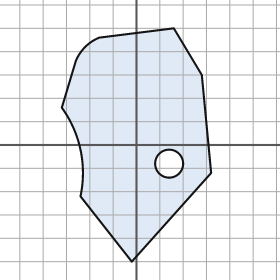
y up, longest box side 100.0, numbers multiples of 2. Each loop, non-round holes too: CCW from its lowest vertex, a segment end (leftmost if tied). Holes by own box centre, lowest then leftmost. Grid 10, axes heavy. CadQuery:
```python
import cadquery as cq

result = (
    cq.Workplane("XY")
    .moveTo(-2.0, -50.0)
    .lineTo(32.0, -12.0)
    .lineTo(28.0, 30.0)
    .lineTo(16.0, 50.0)
    .lineTo(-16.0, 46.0)
    .threePointArc((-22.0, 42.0), (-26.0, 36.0))
    .lineTo(-32.0, 16.0)
    .threePointArc((-24.0, -2.0), (-24.0, -22.0))
    .close()
    .moveTo(14.0, -8.0)
    .circle(6.0)
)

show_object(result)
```